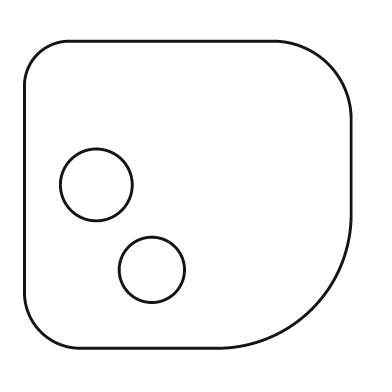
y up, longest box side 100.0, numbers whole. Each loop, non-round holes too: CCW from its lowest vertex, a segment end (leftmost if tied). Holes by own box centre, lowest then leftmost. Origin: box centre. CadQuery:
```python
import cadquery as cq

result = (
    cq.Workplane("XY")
    .moveTo(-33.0, -47.0)
    .lineTo(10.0, -47.0)
    .threePointArc((38.0, -35.0), (50.0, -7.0))
    .lineTo(50.0, 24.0)
    .threePointArc((43.0, 40.0), (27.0, 47.0))
    .lineTo(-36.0, 47.0)
    .threePointArc((-46.0, 43.0), (-50.0, 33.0))
    .lineTo(-50.0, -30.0)
    .threePointArc((-45.0, -42.0), (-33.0, -47.0))
    .close()
    .moveTo(-11.0, -23.0)
    .circle(10.0)
    .moveTo(-28.0, 3.0)
    .circle(11.0)
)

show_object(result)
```